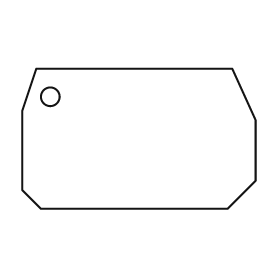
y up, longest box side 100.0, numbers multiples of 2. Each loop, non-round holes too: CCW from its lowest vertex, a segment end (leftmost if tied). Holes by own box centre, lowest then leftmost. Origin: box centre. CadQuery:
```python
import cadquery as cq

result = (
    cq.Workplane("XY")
    .moveTo(-42.0, -30.0)
    .lineTo(38.0, -30.0)
    .lineTo(50.0, -18.0)
    .lineTo(50.0, 8.0)
    .lineTo(40.0, 30.0)
    .lineTo(-44.0, 30.0)
    .lineTo(-50.0, 12.0)
    .lineTo(-50.0, -22.0)
    .close()
    .moveTo(-38.0, 18.0)
    .circle(4.0)
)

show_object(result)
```